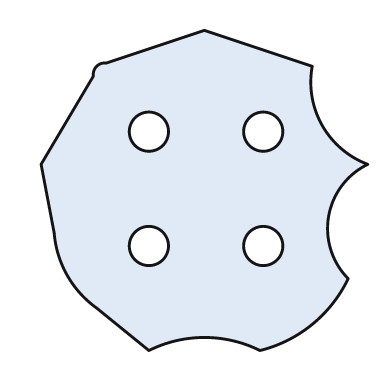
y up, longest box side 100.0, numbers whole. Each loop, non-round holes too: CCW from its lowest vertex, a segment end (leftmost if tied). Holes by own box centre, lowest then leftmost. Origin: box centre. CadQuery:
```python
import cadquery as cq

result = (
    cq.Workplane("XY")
    .moveTo(-17.0, -49.0)
    .threePointArc((0.0, -45.0), (17.0, -49.0))
    .threePointArc((33.0, -41.0), (44.0, -27.0))
    .threePointArc((38.0, -8.0), (50.0, 8.0))
    .threePointArc((36.0, 20.0), (33.0, 38.0))
    .lineTo(0.0, 49.0)
    .lineTo(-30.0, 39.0)
    .threePointArc((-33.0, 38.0), (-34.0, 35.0))
    .lineTo(-50.0, 8.0)
    .lineTo(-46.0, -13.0)
    .threePointArc((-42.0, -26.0), (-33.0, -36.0))
    .close()
    .moveTo(-17.0, -17.0)
    .circle(6.0)
    .moveTo(18.0, -17.0)
    .circle(6.0)
    .moveTo(-17.0, 18.0)
    .circle(6.0)
    .moveTo(18.0, 18.0)
    .circle(6.0)
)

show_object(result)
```